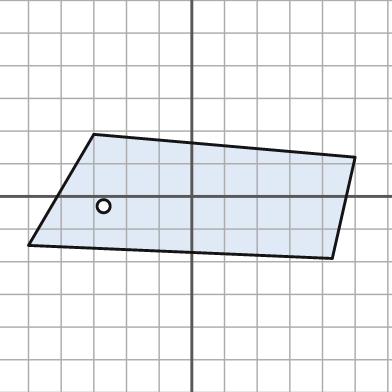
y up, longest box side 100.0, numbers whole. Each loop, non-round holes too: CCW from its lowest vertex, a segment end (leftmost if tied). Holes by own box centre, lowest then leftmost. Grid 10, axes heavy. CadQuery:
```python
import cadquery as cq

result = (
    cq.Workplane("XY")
    .moveTo(43.0, -19.0)
    .lineTo(50.0, 12.0)
    .lineTo(-30.0, 19.0)
    .lineTo(-50.0, -15.0)
    .close()
    .moveTo(-27.0, -3.0)
    .circle(2.0)
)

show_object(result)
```